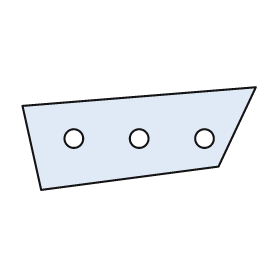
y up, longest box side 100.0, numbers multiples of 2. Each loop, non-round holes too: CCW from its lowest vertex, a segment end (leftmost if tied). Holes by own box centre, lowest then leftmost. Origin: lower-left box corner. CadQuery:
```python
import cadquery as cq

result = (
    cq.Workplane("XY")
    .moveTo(8.0, 0.0)
    .lineTo(84.0, 10.0)
    .lineTo(100.0, 44.0)
    .lineTo(0.0, 36.0)
    .close()
    .moveTo(22.0, 22.0)
    .circle(4.0)
    .moveTo(50.0, 22.0)
    .circle(4.0)
    .moveTo(78.0, 22.0)
    .circle(4.0)
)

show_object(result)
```